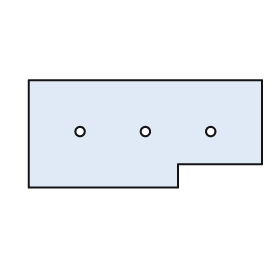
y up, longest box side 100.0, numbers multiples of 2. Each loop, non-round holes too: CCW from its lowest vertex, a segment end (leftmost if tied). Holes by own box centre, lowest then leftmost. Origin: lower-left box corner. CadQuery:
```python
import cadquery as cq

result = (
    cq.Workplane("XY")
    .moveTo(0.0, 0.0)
    .lineTo(64.0, 0.0)
    .lineTo(64.0, 10.0)
    .lineTo(100.0, 10.0)
    .lineTo(100.0, 46.0)
    .lineTo(0.0, 46.0)
    .close()
    .moveTo(22.0, 24.0)
    .circle(2.0)
    .moveTo(50.0, 24.0)
    .circle(2.0)
    .moveTo(78.0, 24.0)
    .circle(2.0)
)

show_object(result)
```